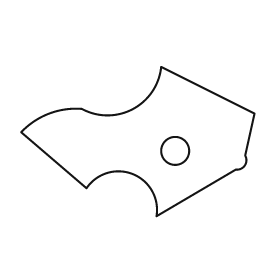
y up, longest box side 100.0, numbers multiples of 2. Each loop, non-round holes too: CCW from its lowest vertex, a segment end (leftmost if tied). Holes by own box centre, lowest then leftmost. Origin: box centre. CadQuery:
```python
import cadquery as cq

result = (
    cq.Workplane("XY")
    .moveTo(8.0, -32.0)
    .lineTo(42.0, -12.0)
    .threePointArc((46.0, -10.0), (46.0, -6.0))
    .lineTo(50.0, 12.0)
    .lineTo(10.0, 32.0)
    .threePointArc((-2.0, 14.0), (-24.0, 14.0))
    .threePointArc((-38.0, 12.0), (-50.0, 4.0))
    .lineTo(-22.0, -20.0)
    .threePointArc((-2.0, -14.0), (8.0, -32.0))
    .close()
    .moveTo(16.0, -4.0)
    .circle(6.0)
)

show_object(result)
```